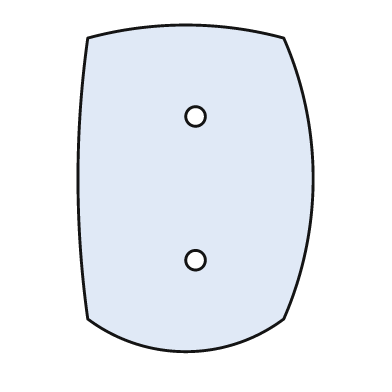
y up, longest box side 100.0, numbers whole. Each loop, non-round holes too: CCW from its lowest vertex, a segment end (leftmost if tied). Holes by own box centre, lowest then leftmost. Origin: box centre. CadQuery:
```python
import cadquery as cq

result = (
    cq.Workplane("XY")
    .moveTo(-33.0, -40.0)
    .threePointArc((-3.0, -50.0), (27.0, -40.0))
    .threePointArc((36.0, 3.0), (27.0, 46.0))
    .threePointArc((-3.0, 50.0), (-33.0, 46.0))
    .threePointArc((-36.0, 3.0), (-33.0, -40.0))
    .close()
    .moveTo(0.0, -22.0)
    .circle(3.0)
    .moveTo(0.0, 22.0)
    .circle(3.0)
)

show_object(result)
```